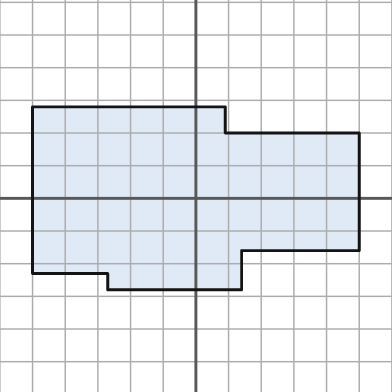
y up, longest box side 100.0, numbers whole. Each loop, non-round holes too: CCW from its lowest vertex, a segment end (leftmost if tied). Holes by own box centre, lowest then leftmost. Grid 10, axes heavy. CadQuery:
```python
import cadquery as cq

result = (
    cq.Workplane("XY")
    .moveTo(-27.0, -28.0)
    .lineTo(14.0, -28.0)
    .lineTo(14.0, -16.0)
    .lineTo(50.0, -16.0)
    .lineTo(50.0, 20.0)
    .lineTo(9.0, 20.0)
    .lineTo(9.0, 28.0)
    .lineTo(-50.0, 28.0)
    .lineTo(-50.0, -23.0)
    .lineTo(-27.0, -23.0)
    .close()
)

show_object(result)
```